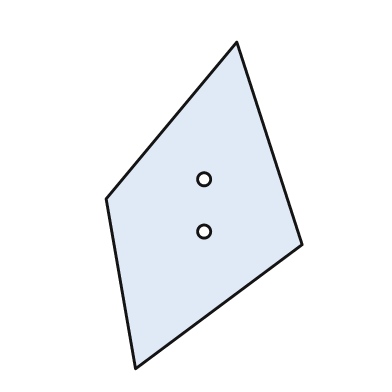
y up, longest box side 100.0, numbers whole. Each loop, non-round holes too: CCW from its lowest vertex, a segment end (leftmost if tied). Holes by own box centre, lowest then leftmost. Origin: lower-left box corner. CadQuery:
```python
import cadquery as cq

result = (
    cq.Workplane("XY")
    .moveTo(9.0, 0.0)
    .lineTo(60.0, 38.0)
    .lineTo(40.0, 100.0)
    .lineTo(0.0, 52.0)
    .close()
    .moveTo(30.0, 42.0)
    .circle(2.0)
    .moveTo(30.0, 58.0)
    .circle(2.0)
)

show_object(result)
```